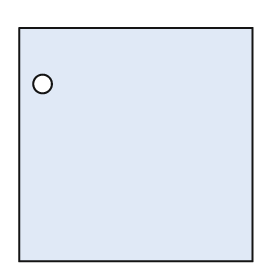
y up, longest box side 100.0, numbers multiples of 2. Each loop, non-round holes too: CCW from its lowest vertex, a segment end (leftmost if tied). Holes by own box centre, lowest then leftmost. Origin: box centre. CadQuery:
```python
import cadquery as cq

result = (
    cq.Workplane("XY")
    .moveTo(-50.0, -50.0)
    .lineTo(50.0, -50.0)
    .lineTo(50.0, 50.0)
    .lineTo(-50.0, 50.0)
    .close()
    .moveTo(-40.0, 26.0)
    .circle(4.0)
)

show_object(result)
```